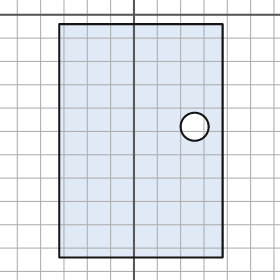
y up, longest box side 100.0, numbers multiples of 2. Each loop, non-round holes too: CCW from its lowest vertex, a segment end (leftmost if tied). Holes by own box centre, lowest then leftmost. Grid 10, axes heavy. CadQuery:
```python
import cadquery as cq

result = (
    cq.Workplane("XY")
    .moveTo(-32.0, -104.0)
    .lineTo(38.0, -104.0)
    .lineTo(38.0, -4.0)
    .lineTo(-32.0, -4.0)
    .close()
    .moveTo(26.0, -48.0)
    .circle(6.0)
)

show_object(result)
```